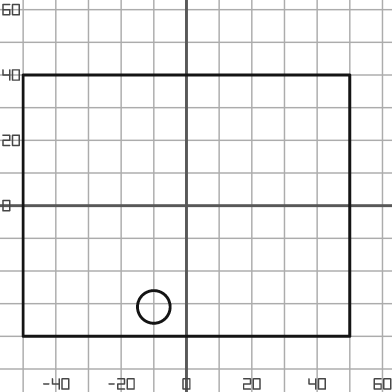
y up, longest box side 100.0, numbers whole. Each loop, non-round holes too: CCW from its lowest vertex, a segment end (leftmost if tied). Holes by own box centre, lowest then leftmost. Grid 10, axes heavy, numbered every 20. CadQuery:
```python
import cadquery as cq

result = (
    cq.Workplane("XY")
    .moveTo(-50.0, -40.0)
    .lineTo(50.0, -40.0)
    .lineTo(50.0, 40.0)
    .lineTo(-50.0, 40.0)
    .close()
    .moveTo(-10.0, -31.0)
    .circle(5.0)
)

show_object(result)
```